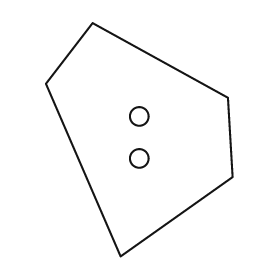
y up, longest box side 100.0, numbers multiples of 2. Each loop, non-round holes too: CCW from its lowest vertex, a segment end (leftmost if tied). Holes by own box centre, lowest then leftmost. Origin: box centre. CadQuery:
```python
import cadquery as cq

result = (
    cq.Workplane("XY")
    .moveTo(-8.0, -50.0)
    .lineTo(40.0, -16.0)
    .lineTo(38.0, 18.0)
    .lineTo(-20.0, 50.0)
    .lineTo(-40.0, 24.0)
    .close()
    .moveTo(0.0, -8.0)
    .circle(4.0)
    .moveTo(0.0, 10.0)
    .circle(4.0)
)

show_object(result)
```